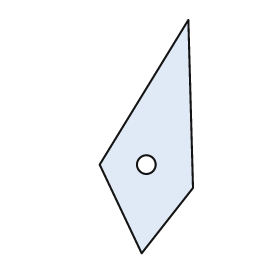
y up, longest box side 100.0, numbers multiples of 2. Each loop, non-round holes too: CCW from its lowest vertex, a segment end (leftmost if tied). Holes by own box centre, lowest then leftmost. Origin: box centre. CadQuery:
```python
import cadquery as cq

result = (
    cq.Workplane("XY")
    .moveTo(-2.0, -50.0)
    .lineTo(20.0, -22.0)
    .lineTo(18.0, 50.0)
    .lineTo(-20.0, -12.0)
    .close()
    .moveTo(0.0, -12.0)
    .circle(4.0)
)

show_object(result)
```